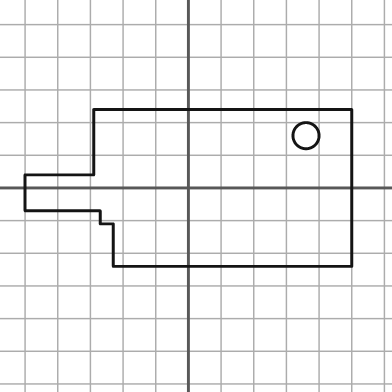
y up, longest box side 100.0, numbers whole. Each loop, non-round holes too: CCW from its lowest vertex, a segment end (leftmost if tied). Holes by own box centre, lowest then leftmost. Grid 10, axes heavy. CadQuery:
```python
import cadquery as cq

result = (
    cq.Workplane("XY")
    .moveTo(-23.0, -24.0)
    .lineTo(50.0, -24.0)
    .lineTo(50.0, 24.0)
    .lineTo(-29.0, 24.0)
    .lineTo(-29.0, 4.0)
    .lineTo(-50.0, 4.0)
    .lineTo(-50.0, -7.0)
    .lineTo(-27.0, -7.0)
    .lineTo(-27.0, -11.0)
    .lineTo(-23.0, -11.0)
    .close()
    .moveTo(36.0, 16.0)
    .circle(4.0)
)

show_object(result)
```